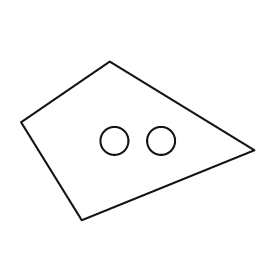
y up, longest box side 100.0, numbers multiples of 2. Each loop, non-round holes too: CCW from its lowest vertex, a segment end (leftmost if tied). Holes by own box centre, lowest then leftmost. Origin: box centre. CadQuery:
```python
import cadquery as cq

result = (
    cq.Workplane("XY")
    .moveTo(-24.0, -34.0)
    .lineTo(50.0, -4.0)
    .lineTo(-12.0, 34.0)
    .lineTo(-50.0, 8.0)
    .close()
    .moveTo(-10.0, 0.0)
    .circle(6.0)
    .moveTo(10.0, 0.0)
    .circle(6.0)
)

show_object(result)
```